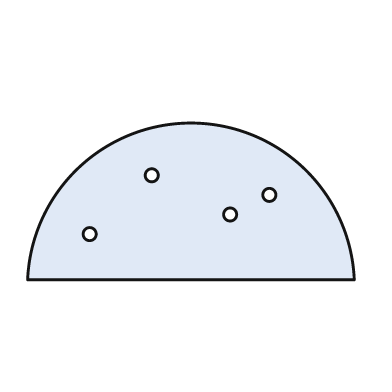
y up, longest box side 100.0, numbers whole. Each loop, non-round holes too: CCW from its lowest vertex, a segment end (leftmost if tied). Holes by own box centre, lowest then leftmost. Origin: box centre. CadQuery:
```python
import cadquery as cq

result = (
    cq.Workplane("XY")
    .moveTo(-50.0, -24.0)
    .lineTo(50.0, -24.0)
    .threePointArc((0.0, 24.0), (-50.0, -24.0))
    .close()
    .moveTo(-31.0, -10.0)
    .circle(2.0)
    .moveTo(12.0, -4.0)
    .circle(2.0)
    .moveTo(24.0, 2.0)
    .circle(2.0)
    .moveTo(-12.0, 8.0)
    .circle(2.0)
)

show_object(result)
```